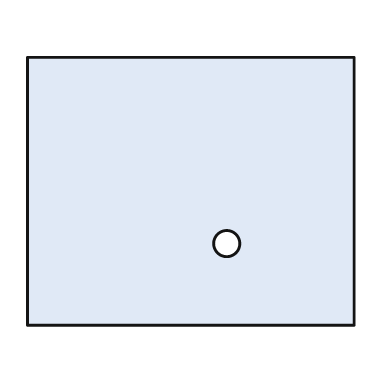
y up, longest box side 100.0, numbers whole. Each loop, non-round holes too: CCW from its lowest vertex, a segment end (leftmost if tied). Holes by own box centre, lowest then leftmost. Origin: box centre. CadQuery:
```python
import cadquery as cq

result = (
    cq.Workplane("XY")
    .moveTo(-50.0, -41.0)
    .lineTo(50.0, -41.0)
    .lineTo(50.0, 41.0)
    .lineTo(-50.0, 41.0)
    .close()
    .moveTo(11.0, -16.0)
    .circle(4.0)
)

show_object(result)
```